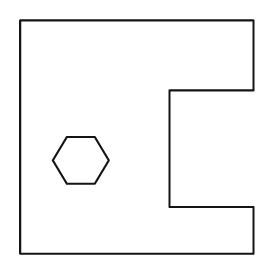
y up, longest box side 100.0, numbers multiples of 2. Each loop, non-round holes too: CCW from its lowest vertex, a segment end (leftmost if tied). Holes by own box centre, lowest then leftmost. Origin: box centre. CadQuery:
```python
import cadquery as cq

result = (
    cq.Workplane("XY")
    .moveTo(-50.0, -50.0)
    .lineTo(50.0, -50.0)
    .lineTo(50.0, -30.0)
    .lineTo(14.0, -30.0)
    .lineTo(14.0, 20.0)
    .lineTo(50.0, 20.0)
    .lineTo(50.0, 50.0)
    .lineTo(-50.0, 50.0)
    .close()
    .moveTo(-30.0, -20.0)
    .lineTo(-18.0, -20.0)
    .lineTo(-12.0, -10.0)
    .lineTo(-18.0, 0.0)
    .lineTo(-30.0, 0.0)
    .lineTo(-36.0, -10.0)
    .close()
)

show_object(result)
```